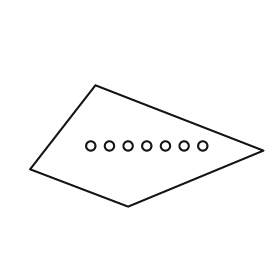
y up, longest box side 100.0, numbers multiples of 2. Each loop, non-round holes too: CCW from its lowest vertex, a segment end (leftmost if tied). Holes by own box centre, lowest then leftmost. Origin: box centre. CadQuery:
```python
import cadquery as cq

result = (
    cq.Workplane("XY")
    .moveTo(-8.0, -26.0)
    .lineTo(50.0, -2.0)
    .lineTo(-22.0, 26.0)
    .lineTo(-50.0, -10.0)
    .close()
    .moveTo(-24.0, 0.0)
    .circle(2.0)
    .moveTo(-16.0, 0.0)
    .circle(2.0)
    .moveTo(-8.0, 0.0)
    .circle(2.0)
    .moveTo(0.0, 0.0)
    .circle(2.0)
    .moveTo(8.0, 0.0)
    .circle(2.0)
    .moveTo(16.0, 0.0)
    .circle(2.0)
    .moveTo(24.0, 0.0)
    .circle(2.0)
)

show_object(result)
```